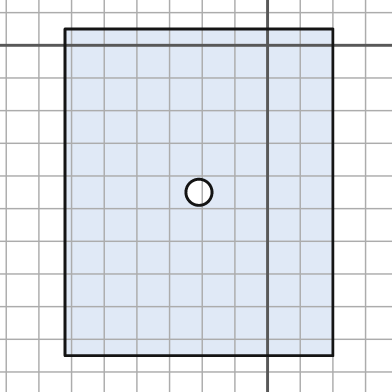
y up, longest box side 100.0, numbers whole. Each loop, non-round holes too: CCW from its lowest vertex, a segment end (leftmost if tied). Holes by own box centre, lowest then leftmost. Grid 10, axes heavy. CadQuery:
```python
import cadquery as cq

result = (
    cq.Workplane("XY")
    .moveTo(-62.0, -95.0)
    .lineTo(20.0, -95.0)
    .lineTo(20.0, 5.0)
    .lineTo(-62.0, 5.0)
    .close()
    .moveTo(-21.0, -45.0)
    .circle(4.0)
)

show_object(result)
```